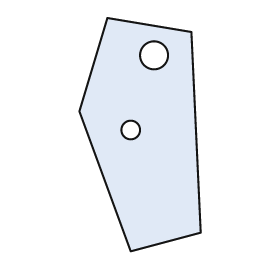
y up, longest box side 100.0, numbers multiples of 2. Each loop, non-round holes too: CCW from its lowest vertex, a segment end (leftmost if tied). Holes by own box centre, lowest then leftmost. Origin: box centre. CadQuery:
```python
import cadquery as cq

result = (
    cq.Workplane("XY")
    .moveTo(-4.0, -50.0)
    .lineTo(26.0, -42.0)
    .lineTo(22.0, 44.0)
    .lineTo(-14.0, 50.0)
    .lineTo(-26.0, 10.0)
    .close()
    .moveTo(-4.0, 2.0)
    .circle(4.0)
    .moveTo(6.0, 34.0)
    .circle(6.0)
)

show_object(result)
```